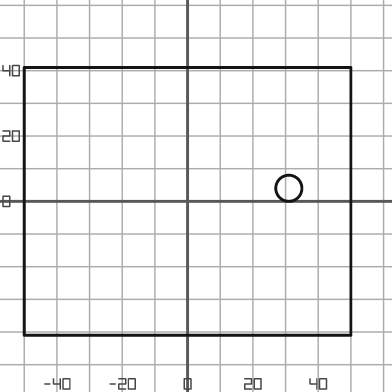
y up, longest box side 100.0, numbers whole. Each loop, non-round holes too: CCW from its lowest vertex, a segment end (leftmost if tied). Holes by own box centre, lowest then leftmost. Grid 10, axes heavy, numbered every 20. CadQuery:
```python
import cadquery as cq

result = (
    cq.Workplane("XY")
    .moveTo(-50.0, -41.0)
    .lineTo(50.0, -41.0)
    .lineTo(50.0, 41.0)
    .lineTo(-50.0, 41.0)
    .close()
    .moveTo(31.0, 4.0)
    .circle(4.0)
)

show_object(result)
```